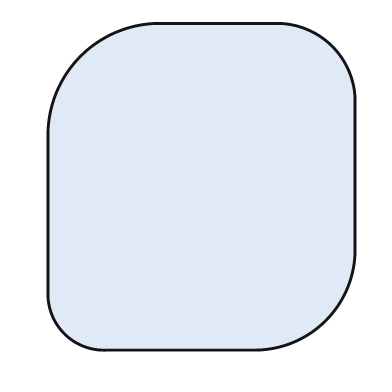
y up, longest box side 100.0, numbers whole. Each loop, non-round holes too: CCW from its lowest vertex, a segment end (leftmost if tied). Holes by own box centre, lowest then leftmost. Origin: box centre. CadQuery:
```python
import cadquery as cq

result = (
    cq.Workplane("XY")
    .moveTo(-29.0, -50.0)
    .lineTo(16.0, -50.0)
    .threePointArc((38.0, -41.0), (47.0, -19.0))
    .lineTo(47.0, 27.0)
    .threePointArc((40.0, 43.0), (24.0, 50.0))
    .lineTo(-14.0, 50.0)
    .threePointArc((-37.0, 40.0), (-47.0, 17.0))
    .lineTo(-47.0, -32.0)
    .threePointArc((-42.0, -45.0), (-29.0, -50.0))
    .close()
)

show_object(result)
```